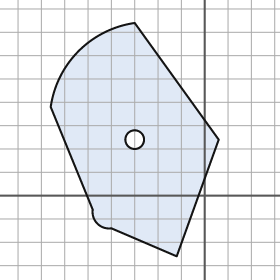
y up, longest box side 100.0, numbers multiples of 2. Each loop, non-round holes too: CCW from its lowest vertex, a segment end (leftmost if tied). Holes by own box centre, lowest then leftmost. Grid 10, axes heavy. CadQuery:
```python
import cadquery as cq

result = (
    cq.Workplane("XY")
    .moveTo(-12.0, -26.0)
    .lineTo(6.0, 24.0)
    .lineTo(-30.0, 74.0)
    .threePointArc((-54.0, 62.0), (-66.0, 38.0))
    .lineTo(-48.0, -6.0)
    .threePointArc((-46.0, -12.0), (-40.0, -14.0))
    .close()
    .moveTo(-30.0, 24.0)
    .circle(4.0)
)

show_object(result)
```